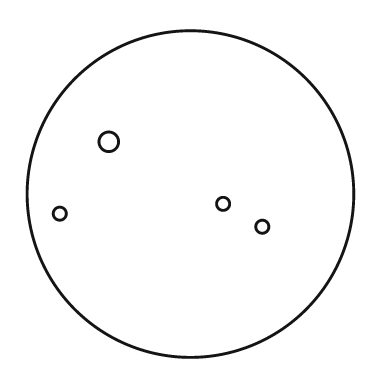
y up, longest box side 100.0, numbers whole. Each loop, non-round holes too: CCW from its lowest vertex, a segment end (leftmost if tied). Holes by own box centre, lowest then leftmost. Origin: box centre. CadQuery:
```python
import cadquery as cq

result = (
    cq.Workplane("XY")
    .moveTo(0.0, 0.0)
    .circle(50.0)
    .moveTo(22.0, -10.0)
    .circle(2.0)
    .moveTo(-40.0, -6.0)
    .circle(2.0)
    .moveTo(10.0, -3.0)
    .circle(2.0)
    .moveTo(-25.0, 16.0)
    .circle(3.0)
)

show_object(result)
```